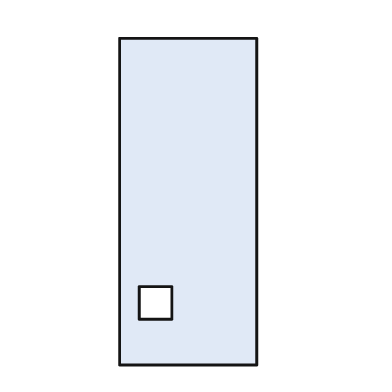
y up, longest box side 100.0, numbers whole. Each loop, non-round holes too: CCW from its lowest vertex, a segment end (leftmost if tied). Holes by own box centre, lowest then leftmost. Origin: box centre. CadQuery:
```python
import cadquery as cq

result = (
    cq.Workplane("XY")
    .moveTo(-21.0, -50.0)
    .lineTo(21.0, -50.0)
    .lineTo(21.0, 50.0)
    .lineTo(-21.0, 50.0)
    .close()
    .moveTo(-15.0, -36.0)
    .lineTo(-5.0, -36.0)
    .lineTo(-5.0, -26.0)
    .lineTo(-15.0, -26.0)
    .close()
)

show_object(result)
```